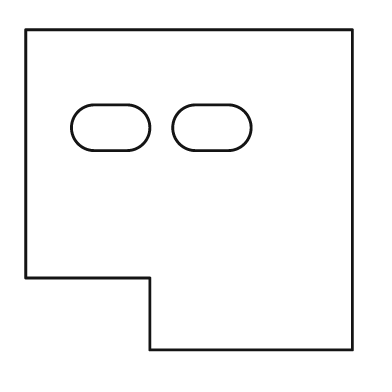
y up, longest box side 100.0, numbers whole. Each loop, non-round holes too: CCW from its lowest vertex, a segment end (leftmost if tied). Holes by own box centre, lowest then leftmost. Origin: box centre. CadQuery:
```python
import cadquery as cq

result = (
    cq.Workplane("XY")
    .moveTo(-12.0, -49.0)
    .lineTo(50.0, -49.0)
    .lineTo(50.0, 49.0)
    .lineTo(-50.0, 49.0)
    .lineTo(-50.0, -27.0)
    .lineTo(-12.0, -27.0)
    .close()
    .moveTo(-29.0, 12.0)
    .lineTo(-19.0, 12.0)
    .threePointArc((-12.0, 19.0), (-19.0, 26.0))
    .lineTo(-29.0, 26.0)
    .threePointArc((-36.0, 19.0), (-29.0, 12.0))
    .close()
    .moveTo(2.0, 12.0)
    .lineTo(12.0, 12.0)
    .threePointArc((19.0, 19.0), (12.0, 26.0))
    .lineTo(2.0, 26.0)
    .threePointArc((-5.0, 19.0), (2.0, 12.0))
    .close()
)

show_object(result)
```